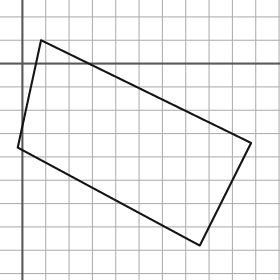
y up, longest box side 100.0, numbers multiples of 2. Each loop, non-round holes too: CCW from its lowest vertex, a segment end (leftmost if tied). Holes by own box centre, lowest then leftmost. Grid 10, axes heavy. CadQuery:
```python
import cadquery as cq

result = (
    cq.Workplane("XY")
    .moveTo(76.0, -78.0)
    .lineTo(98.0, -34.0)
    .lineTo(8.0, 10.0)
    .lineTo(-2.0, -36.0)
    .close()
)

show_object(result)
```